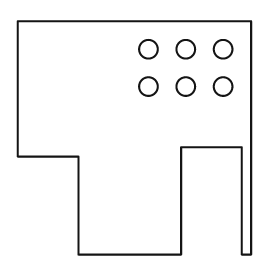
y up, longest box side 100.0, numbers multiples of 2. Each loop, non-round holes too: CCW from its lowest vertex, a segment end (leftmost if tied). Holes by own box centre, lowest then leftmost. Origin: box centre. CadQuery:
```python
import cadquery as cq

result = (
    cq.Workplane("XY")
    .moveTo(-24.0, -50.0)
    .lineTo(20.0, -50.0)
    .lineTo(20.0, -4.0)
    .lineTo(46.0, -4.0)
    .lineTo(46.0, -50.0)
    .lineTo(50.0, -50.0)
    .lineTo(50.0, 50.0)
    .lineTo(-50.0, 50.0)
    .lineTo(-50.0, -8.0)
    .lineTo(-24.0, -8.0)
    .close()
    .moveTo(6.0, 22.0)
    .circle(4.0)
    .moveTo(22.0, 22.0)
    .circle(4.0)
    .moveTo(38.0, 22.0)
    .circle(4.0)
    .moveTo(6.0, 38.0)
    .circle(4.0)
    .moveTo(22.0, 38.0)
    .circle(4.0)
    .moveTo(38.0, 38.0)
    .circle(4.0)
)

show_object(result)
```